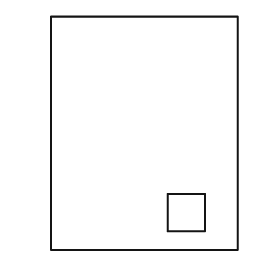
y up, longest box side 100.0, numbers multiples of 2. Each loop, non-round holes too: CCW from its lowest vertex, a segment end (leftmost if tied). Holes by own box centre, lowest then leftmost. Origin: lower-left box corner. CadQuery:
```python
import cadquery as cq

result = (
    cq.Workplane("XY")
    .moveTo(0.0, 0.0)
    .lineTo(80.0, 0.0)
    .lineTo(80.0, 100.0)
    .lineTo(0.0, 100.0)
    .close()
    .moveTo(50.0, 8.0)
    .lineTo(66.0, 8.0)
    .lineTo(66.0, 24.0)
    .lineTo(50.0, 24.0)
    .close()
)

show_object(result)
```